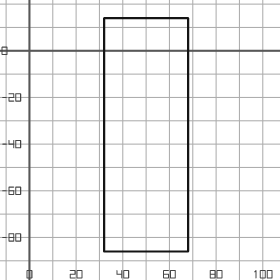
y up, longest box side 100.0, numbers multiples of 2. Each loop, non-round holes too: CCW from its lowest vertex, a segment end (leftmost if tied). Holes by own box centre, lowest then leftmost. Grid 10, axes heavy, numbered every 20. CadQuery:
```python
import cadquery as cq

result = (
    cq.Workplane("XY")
    .moveTo(32.0, -86.0)
    .lineTo(68.0, -86.0)
    .lineTo(68.0, 14.0)
    .lineTo(32.0, 14.0)
    .close()
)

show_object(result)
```